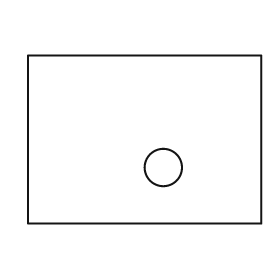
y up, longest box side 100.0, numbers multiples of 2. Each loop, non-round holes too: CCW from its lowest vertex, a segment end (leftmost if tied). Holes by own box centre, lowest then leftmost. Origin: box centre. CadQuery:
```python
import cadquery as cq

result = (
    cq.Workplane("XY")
    .moveTo(-50.0, -36.0)
    .lineTo(50.0, -36.0)
    .lineTo(50.0, 36.0)
    .lineTo(-50.0, 36.0)
    .close()
    .moveTo(8.0, -12.0)
    .circle(8.0)
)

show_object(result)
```